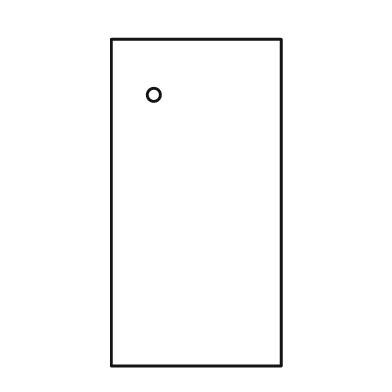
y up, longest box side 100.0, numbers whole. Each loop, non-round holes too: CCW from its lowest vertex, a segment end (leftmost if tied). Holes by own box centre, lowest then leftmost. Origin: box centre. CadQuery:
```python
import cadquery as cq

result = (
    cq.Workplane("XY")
    .moveTo(-26.0, -50.0)
    .lineTo(26.0, -50.0)
    .lineTo(26.0, 50.0)
    .lineTo(-26.0, 50.0)
    .close()
    .moveTo(-13.0, 33.0)
    .circle(2.0)
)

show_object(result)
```